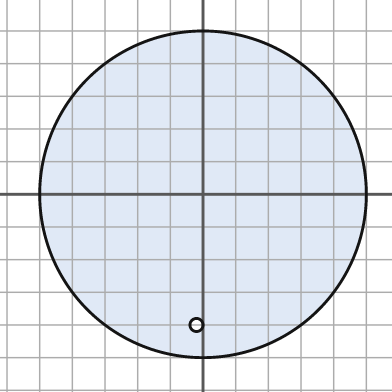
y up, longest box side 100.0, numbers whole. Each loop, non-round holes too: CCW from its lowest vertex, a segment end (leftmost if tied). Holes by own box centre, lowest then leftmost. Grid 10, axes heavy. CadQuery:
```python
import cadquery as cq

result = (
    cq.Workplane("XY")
    .moveTo(0.0, 0.0)
    .circle(50.0)
    .moveTo(-2.0, -40.0)
    .circle(2.0)
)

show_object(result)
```